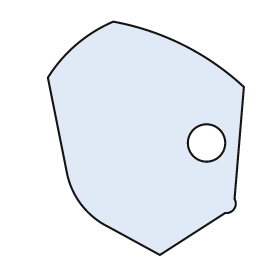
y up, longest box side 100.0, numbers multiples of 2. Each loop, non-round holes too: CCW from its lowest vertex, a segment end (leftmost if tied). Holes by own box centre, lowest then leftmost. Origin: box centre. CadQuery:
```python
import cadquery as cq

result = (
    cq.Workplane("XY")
    .moveTo(6.0, -50.0)
    .lineTo(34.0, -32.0)
    .threePointArc((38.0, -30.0), (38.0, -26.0))
    .lineTo(42.0, 22.0)
    .threePointArc((16.0, 40.0), (-14.0, 50.0))
    .threePointArc((-30.0, 40.0), (-42.0, 26.0))
    .lineTo(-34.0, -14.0)
    .threePointArc((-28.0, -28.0), (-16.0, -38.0))
    .close()
    .moveTo(26.0, -2.0)
    .circle(8.0)
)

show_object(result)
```